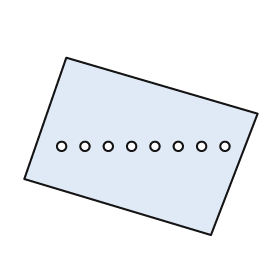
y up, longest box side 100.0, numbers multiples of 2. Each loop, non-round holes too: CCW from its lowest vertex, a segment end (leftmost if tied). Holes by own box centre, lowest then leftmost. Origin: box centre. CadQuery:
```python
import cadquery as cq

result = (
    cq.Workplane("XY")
    .moveTo(30.0, -38.0)
    .lineTo(50.0, 14.0)
    .lineTo(-32.0, 38.0)
    .lineTo(-50.0, -14.0)
    .close()
    .moveTo(-34.0, 0.0)
    .circle(2.0)
    .moveTo(-24.0, 0.0)
    .circle(2.0)
    .moveTo(-14.0, 0.0)
    .circle(2.0)
    .moveTo(-4.0, 0.0)
    .circle(2.0)
    .moveTo(6.0, 0.0)
    .circle(2.0)
    .moveTo(16.0, 0.0)
    .circle(2.0)
    .moveTo(26.0, 0.0)
    .circle(2.0)
    .moveTo(36.0, 0.0)
    .circle(2.0)
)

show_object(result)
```